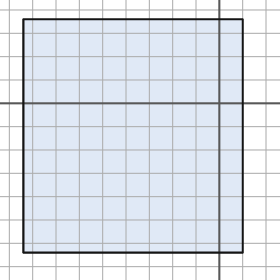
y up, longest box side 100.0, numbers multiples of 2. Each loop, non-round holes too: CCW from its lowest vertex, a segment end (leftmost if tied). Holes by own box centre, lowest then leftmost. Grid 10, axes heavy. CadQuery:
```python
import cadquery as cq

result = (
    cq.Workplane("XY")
    .moveTo(-84.0, -64.0)
    .lineTo(10.0, -64.0)
    .lineTo(10.0, 36.0)
    .lineTo(-84.0, 36.0)
    .close()
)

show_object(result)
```